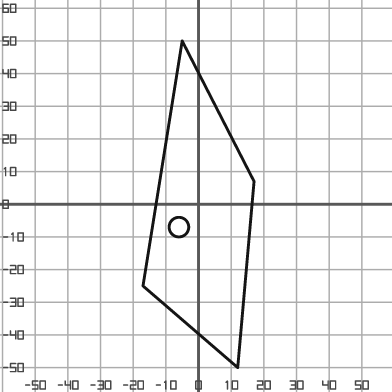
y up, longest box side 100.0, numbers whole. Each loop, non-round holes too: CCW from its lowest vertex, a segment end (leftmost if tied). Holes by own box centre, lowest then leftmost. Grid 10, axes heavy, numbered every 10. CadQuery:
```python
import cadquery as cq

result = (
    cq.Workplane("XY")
    .moveTo(12.0, -50.0)
    .lineTo(17.0, 7.0)
    .lineTo(-5.0, 50.0)
    .lineTo(-17.0, -25.0)
    .close()
    .moveTo(-6.0, -7.0)
    .circle(3.0)
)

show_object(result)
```